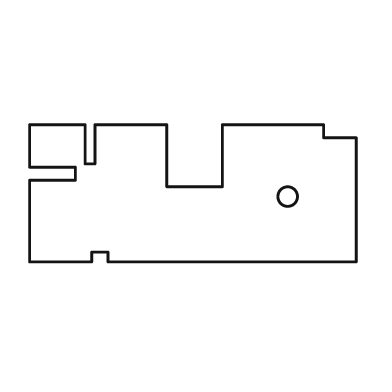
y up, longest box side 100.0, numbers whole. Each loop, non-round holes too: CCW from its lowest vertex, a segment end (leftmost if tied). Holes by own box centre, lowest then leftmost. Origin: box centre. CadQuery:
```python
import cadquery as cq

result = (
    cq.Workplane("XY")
    .moveTo(-50.0, -21.0)
    .lineTo(-31.0, -21.0)
    .lineTo(-31.0, -18.0)
    .lineTo(-26.0, -18.0)
    .lineTo(-26.0, -21.0)
    .lineTo(50.0, -21.0)
    .lineTo(50.0, 17.0)
    .lineTo(40.0, 17.0)
    .lineTo(40.0, 21.0)
    .lineTo(9.0, 21.0)
    .lineTo(9.0, 2.0)
    .lineTo(-8.0, 2.0)
    .lineTo(-8.0, 21.0)
    .lineTo(-30.0, 21.0)
    .lineTo(-30.0, 9.0)
    .lineTo(-33.0, 9.0)
    .lineTo(-33.0, 21.0)
    .lineTo(-50.0, 21.0)
    .lineTo(-50.0, 8.0)
    .lineTo(-36.0, 8.0)
    .lineTo(-36.0, 4.0)
    .lineTo(-50.0, 4.0)
    .close()
    .moveTo(29.0, -1.0)
    .circle(3.0)
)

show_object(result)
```